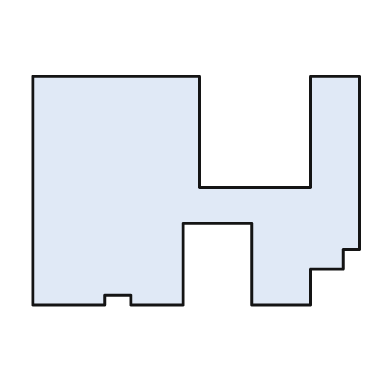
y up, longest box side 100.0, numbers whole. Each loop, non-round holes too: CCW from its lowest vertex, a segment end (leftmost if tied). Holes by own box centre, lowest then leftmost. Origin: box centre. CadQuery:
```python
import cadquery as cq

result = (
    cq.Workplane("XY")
    .moveTo(-50.0, -35.0)
    .lineTo(-28.0, -35.0)
    .lineTo(-28.0, -32.0)
    .lineTo(-20.0, -32.0)
    .lineTo(-20.0, -35.0)
    .lineTo(-4.0, -35.0)
    .lineTo(-4.0, -10.0)
    .lineTo(17.0, -10.0)
    .lineTo(17.0, -35.0)
    .lineTo(35.0, -35.0)
    .lineTo(35.0, -24.0)
    .lineTo(45.0, -24.0)
    .lineTo(45.0, -18.0)
    .lineTo(50.0, -18.0)
    .lineTo(50.0, 35.0)
    .lineTo(35.0, 35.0)
    .lineTo(35.0, 1.0)
    .lineTo(1.0, 1.0)
    .lineTo(1.0, 35.0)
    .lineTo(-50.0, 35.0)
    .close()
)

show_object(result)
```